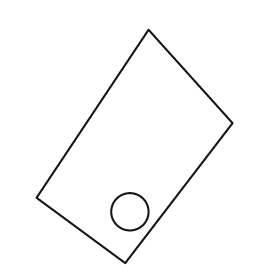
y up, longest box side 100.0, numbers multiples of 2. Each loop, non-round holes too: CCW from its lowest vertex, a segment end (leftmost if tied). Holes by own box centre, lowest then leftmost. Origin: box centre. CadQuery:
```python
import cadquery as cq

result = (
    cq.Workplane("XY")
    .moveTo(-4.0, -50.0)
    .lineTo(42.0, 10.0)
    .lineTo(6.0, 50.0)
    .lineTo(-42.0, -22.0)
    .close()
    .moveTo(-2.0, -28.0)
    .circle(8.0)
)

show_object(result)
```